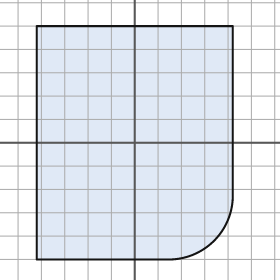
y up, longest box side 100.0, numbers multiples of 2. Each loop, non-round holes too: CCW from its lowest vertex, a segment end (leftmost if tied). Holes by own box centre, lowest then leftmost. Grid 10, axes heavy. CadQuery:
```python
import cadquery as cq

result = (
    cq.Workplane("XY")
    .moveTo(-42.0, -50.0)
    .lineTo(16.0, -50.0)
    .threePointArc((34.0, -42.0), (42.0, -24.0))
    .lineTo(42.0, 50.0)
    .lineTo(-42.0, 50.0)
    .close()
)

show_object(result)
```